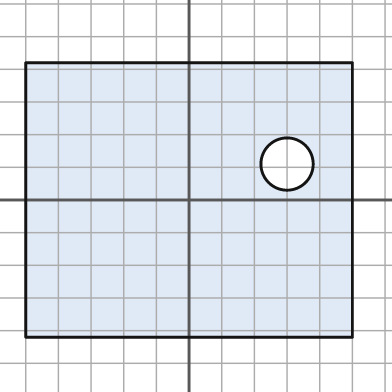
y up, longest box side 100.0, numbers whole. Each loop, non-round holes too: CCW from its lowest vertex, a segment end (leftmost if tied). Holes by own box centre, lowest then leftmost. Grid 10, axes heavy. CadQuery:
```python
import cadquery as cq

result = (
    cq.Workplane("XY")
    .moveTo(-50.0, -42.0)
    .lineTo(50.0, -42.0)
    .lineTo(50.0, 42.0)
    .lineTo(-50.0, 42.0)
    .close()
    .moveTo(30.0, 11.0)
    .circle(8.0)
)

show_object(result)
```